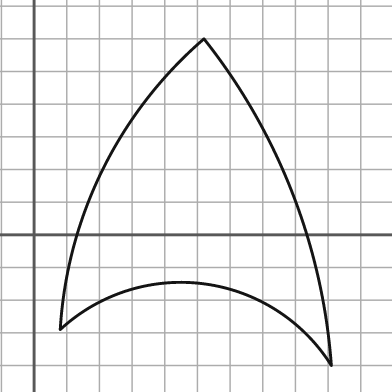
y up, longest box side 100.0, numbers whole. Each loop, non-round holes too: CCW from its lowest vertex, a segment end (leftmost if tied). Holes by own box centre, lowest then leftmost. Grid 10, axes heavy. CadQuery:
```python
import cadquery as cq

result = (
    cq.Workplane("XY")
    .moveTo(91.0, -40.0)
    .threePointArc((79.0, 13.0), (52.0, 60.0))
    .threePointArc((21.0, 20.0), (8.0, -29.0))
    .threePointArc((52.0, -15.0), (91.0, -40.0))
    .close()
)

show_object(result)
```